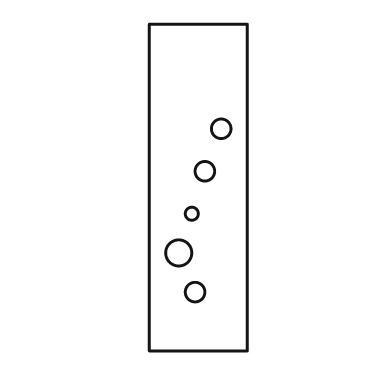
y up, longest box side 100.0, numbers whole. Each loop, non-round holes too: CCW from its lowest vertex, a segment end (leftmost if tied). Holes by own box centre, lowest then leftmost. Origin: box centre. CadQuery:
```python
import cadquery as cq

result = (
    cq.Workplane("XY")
    .moveTo(-15.0, -50.0)
    .lineTo(15.0, -50.0)
    .lineTo(15.0, 50.0)
    .lineTo(-15.0, 50.0)
    .close()
    .moveTo(-1.0, -32.0)
    .circle(3.0)
    .moveTo(-6.0, -20.0)
    .circle(4.0)
    .moveTo(-2.0, -8.0)
    .circle(2.0)
    .moveTo(2.0, 5.0)
    .circle(3.0)
    .moveTo(7.0, 18.0)
    .circle(3.0)
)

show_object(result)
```